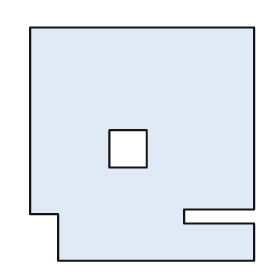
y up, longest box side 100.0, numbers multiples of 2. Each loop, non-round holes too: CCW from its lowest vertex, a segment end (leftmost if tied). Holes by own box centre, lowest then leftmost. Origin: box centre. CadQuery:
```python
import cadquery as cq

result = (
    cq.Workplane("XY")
    .moveTo(-36.0, -50.0)
    .lineTo(48.0, -50.0)
    .lineTo(48.0, -34.0)
    .lineTo(18.0, -34.0)
    .lineTo(18.0, -28.0)
    .lineTo(48.0, -28.0)
    .lineTo(48.0, 50.0)
    .lineTo(-48.0, 50.0)
    .lineTo(-48.0, -30.0)
    .lineTo(-36.0, -30.0)
    .close()
    .moveTo(-14.0, -10.0)
    .lineTo(2.0, -10.0)
    .lineTo(2.0, 6.0)
    .lineTo(-14.0, 6.0)
    .close()
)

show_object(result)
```